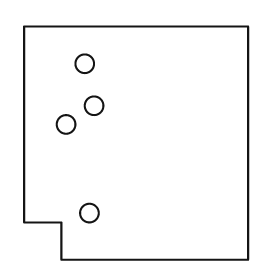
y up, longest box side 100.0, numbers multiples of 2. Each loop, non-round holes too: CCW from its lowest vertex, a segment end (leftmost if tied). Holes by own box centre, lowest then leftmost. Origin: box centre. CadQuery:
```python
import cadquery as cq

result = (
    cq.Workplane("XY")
    .moveTo(-32.0, -50.0)
    .lineTo(48.0, -50.0)
    .lineTo(48.0, 50.0)
    .lineTo(-48.0, 50.0)
    .lineTo(-48.0, -34.0)
    .lineTo(-32.0, -34.0)
    .close()
    .moveTo(-20.0, -30.0)
    .circle(4.0)
    .moveTo(-30.0, 8.0)
    .circle(4.0)
    .moveTo(-18.0, 16.0)
    .circle(4.0)
    .moveTo(-22.0, 34.0)
    .circle(4.0)
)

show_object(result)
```